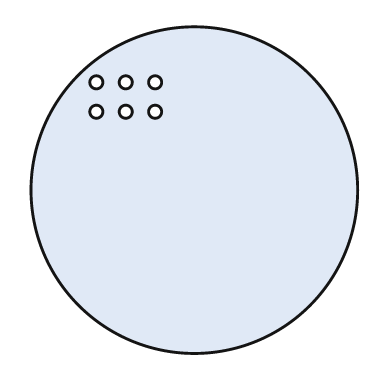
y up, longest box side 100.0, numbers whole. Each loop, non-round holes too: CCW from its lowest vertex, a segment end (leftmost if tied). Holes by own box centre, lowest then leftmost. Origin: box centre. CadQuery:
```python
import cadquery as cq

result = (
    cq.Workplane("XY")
    .moveTo(0.0, 0.0)
    .circle(50.0)
    .moveTo(-30.0, 24.0)
    .circle(2.0)
    .moveTo(-21.0, 24.0)
    .circle(2.0)
    .moveTo(-12.0, 24.0)
    .circle(2.0)
    .moveTo(-30.0, 33.0)
    .circle(2.0)
    .moveTo(-21.0, 33.0)
    .circle(2.0)
    .moveTo(-12.0, 33.0)
    .circle(2.0)
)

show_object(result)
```